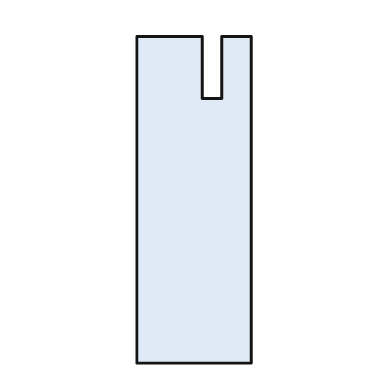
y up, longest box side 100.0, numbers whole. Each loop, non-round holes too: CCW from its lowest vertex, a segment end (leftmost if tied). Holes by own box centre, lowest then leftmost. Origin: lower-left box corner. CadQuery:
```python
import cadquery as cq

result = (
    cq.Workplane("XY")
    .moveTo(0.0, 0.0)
    .lineTo(35.0, 0.0)
    .lineTo(35.0, 100.0)
    .lineTo(26.0, 100.0)
    .lineTo(26.0, 81.0)
    .lineTo(20.0, 81.0)
    .lineTo(20.0, 100.0)
    .lineTo(0.0, 100.0)
    .close()
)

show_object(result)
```